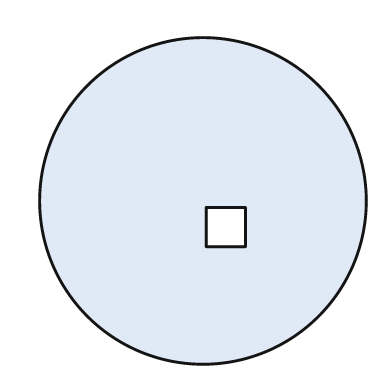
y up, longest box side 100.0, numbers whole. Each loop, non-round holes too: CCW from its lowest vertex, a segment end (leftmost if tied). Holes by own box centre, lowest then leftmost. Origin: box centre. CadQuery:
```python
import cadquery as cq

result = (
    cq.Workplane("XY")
    .moveTo(0.0, 0.0)
    .circle(50.0)
    .moveTo(1.0, -14.0)
    .lineTo(13.0, -14.0)
    .lineTo(13.0, -2.0)
    .lineTo(1.0, -2.0)
    .close()
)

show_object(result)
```